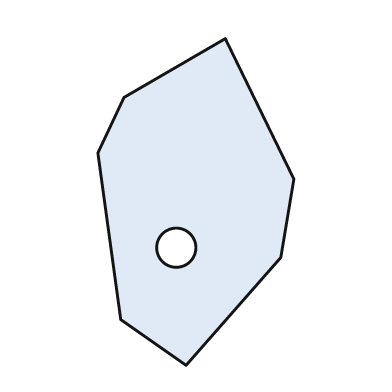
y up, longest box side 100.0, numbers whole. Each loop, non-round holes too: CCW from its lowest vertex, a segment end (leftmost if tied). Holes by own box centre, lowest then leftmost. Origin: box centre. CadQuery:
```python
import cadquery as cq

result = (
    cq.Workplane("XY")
    .moveTo(-3.0, -50.0)
    .lineTo(26.0, -17.0)
    .lineTo(30.0, 7.0)
    .lineTo(9.0, 50.0)
    .lineTo(-22.0, 32.0)
    .lineTo(-30.0, 15.0)
    .lineTo(-23.0, -36.0)
    .close()
    .moveTo(-6.0, -14.0)
    .circle(6.0)
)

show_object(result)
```